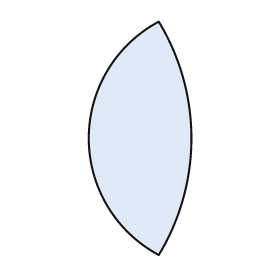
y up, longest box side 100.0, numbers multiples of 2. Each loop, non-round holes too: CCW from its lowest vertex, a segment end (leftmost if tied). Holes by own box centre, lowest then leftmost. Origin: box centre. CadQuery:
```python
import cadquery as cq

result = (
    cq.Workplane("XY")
    .moveTo(8.0, -50.0)
    .threePointArc((22.0, 0.0), (8.0, 50.0))
    .threePointArc((-22.0, 0.0), (8.0, -50.0))
    .close()
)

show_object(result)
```